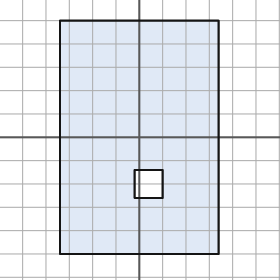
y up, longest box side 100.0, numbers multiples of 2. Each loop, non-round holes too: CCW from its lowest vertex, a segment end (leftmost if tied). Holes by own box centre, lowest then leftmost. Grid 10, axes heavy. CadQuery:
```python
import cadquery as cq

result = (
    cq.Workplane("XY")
    .moveTo(-34.0, -50.0)
    .lineTo(34.0, -50.0)
    .lineTo(34.0, 50.0)
    .lineTo(-34.0, 50.0)
    .close()
    .moveTo(-2.0, -26.0)
    .lineTo(10.0, -26.0)
    .lineTo(10.0, -14.0)
    .lineTo(-2.0, -14.0)
    .close()
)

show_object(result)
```